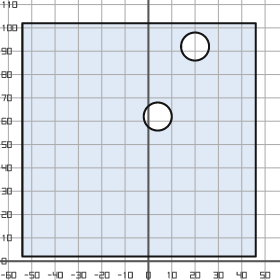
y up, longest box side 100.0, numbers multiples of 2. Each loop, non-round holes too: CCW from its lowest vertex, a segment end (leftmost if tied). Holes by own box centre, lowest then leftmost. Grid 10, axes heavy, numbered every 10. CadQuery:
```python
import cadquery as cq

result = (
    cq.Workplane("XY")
    .moveTo(-54.0, 2.0)
    .lineTo(46.0, 2.0)
    .lineTo(46.0, 102.0)
    .lineTo(-54.0, 102.0)
    .close()
    .moveTo(4.0, 62.0)
    .circle(6.0)
    .moveTo(20.0, 92.0)
    .circle(6.0)
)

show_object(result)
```